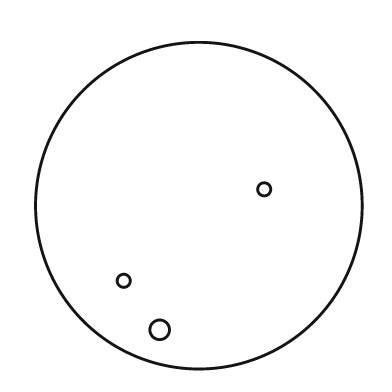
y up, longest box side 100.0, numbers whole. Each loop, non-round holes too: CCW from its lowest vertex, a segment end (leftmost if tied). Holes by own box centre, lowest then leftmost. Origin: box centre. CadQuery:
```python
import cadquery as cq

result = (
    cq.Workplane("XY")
    .moveTo(0.0, 0.0)
    .circle(50.0)
    .moveTo(-12.0, -38.0)
    .circle(3.0)
    .moveTo(-23.0, -23.0)
    .circle(2.0)
    .moveTo(20.0, 5.0)
    .circle(2.0)
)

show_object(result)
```